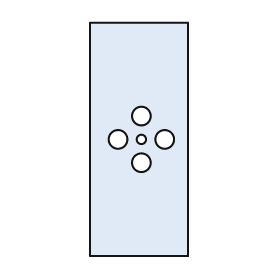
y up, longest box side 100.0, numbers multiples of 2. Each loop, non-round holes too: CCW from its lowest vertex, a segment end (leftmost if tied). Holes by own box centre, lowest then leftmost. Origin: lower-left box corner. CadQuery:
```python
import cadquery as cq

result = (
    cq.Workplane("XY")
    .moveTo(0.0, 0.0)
    .lineTo(42.0, 0.0)
    .lineTo(42.0, 100.0)
    .lineTo(0.0, 100.0)
    .close()
    .moveTo(22.0, 40.0)
    .circle(4.0)
    .moveTo(12.0, 50.0)
    .circle(4.0)
    .moveTo(22.0, 50.0)
    .circle(2.0)
    .moveTo(32.0, 50.0)
    .circle(4.0)
    .moveTo(22.0, 60.0)
    .circle(4.0)
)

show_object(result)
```